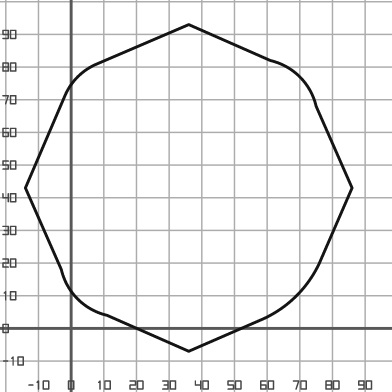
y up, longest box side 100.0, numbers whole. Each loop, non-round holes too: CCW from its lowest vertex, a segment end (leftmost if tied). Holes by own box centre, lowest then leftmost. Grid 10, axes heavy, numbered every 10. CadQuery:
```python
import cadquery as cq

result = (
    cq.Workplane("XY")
    .moveTo(36.0, -7.0)
    .lineTo(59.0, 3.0)
    .threePointArc((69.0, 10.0), (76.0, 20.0))
    .lineTo(86.0, 43.0)
    .lineTo(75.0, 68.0)
    .threePointArc((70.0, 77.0), (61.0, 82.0))
    .lineTo(36.0, 93.0)
    .lineTo(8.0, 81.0)
    .threePointArc((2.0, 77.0), (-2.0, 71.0))
    .lineTo(-14.0, 43.0)
    .lineTo(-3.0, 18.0)
    .threePointArc((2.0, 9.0), (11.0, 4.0))
    .close()
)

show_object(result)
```